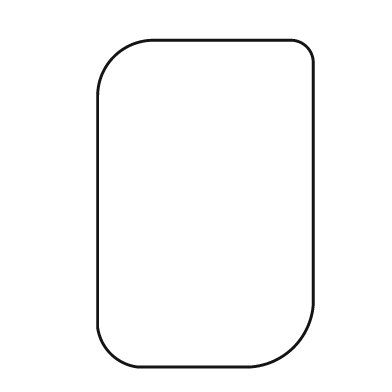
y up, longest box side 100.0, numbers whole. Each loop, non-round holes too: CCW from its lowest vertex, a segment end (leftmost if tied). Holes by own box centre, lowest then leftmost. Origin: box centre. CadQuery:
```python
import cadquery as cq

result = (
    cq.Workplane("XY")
    .moveTo(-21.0, -50.0)
    .lineTo(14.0, -50.0)
    .threePointArc((27.0, -44.0), (33.0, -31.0))
    .lineTo(33.0, 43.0)
    .threePointArc((31.0, 48.0), (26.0, 50.0))
    .lineTo(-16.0, 50.0)
    .threePointArc((-28.0, 45.0), (-33.0, 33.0))
    .lineTo(-33.0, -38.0)
    .threePointArc((-29.0, -46.0), (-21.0, -50.0))
    .close()
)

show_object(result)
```